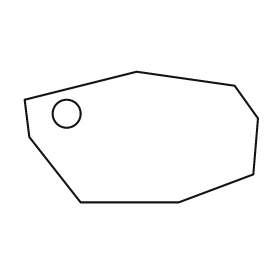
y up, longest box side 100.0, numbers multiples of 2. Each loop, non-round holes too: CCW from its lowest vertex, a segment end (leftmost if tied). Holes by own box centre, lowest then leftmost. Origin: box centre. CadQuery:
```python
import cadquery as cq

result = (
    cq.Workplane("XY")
    .moveTo(-26.0, -28.0)
    .lineTo(16.0, -28.0)
    .lineTo(48.0, -16.0)
    .lineTo(50.0, 8.0)
    .lineTo(40.0, 22.0)
    .lineTo(-2.0, 28.0)
    .lineTo(-50.0, 16.0)
    .lineTo(-48.0, 0.0)
    .close()
    .moveTo(-32.0, 10.0)
    .circle(6.0)
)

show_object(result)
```